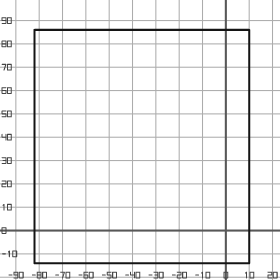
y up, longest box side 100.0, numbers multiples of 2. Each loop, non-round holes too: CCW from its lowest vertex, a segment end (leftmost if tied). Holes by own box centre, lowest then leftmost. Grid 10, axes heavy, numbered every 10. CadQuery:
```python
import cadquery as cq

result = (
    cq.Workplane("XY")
    .moveTo(-82.0, -14.0)
    .lineTo(10.0, -14.0)
    .lineTo(10.0, 86.0)
    .lineTo(-82.0, 86.0)
    .close()
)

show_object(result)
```